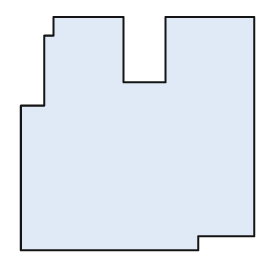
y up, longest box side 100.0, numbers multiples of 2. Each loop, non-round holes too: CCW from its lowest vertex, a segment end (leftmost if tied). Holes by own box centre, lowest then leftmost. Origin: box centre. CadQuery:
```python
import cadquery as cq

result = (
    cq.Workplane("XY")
    .moveTo(-50.0, -50.0)
    .lineTo(26.0, -50.0)
    .lineTo(26.0, -44.0)
    .lineTo(50.0, -44.0)
    .lineTo(50.0, 50.0)
    .lineTo(12.0, 50.0)
    .lineTo(12.0, 22.0)
    .lineTo(-6.0, 22.0)
    .lineTo(-6.0, 50.0)
    .lineTo(-36.0, 50.0)
    .lineTo(-36.0, 42.0)
    .lineTo(-40.0, 42.0)
    .lineTo(-40.0, 12.0)
    .lineTo(-50.0, 12.0)
    .close()
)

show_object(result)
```